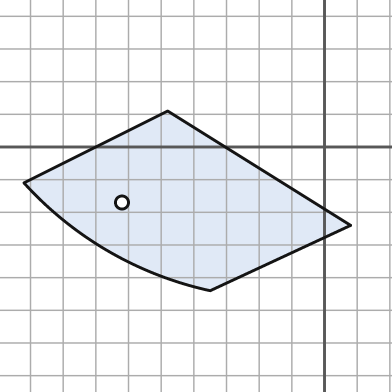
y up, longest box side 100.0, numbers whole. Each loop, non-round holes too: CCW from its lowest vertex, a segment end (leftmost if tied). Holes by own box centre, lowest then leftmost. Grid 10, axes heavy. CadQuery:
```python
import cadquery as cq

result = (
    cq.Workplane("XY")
    .moveTo(-35.0, -44.0)
    .lineTo(8.0, -24.0)
    .lineTo(-48.0, 11.0)
    .lineTo(-92.0, -11.0)
    .threePointArc((-66.0, -32.0), (-35.0, -44.0))
    .close()
    .moveTo(-62.0, -17.0)
    .circle(2.0)
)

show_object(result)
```